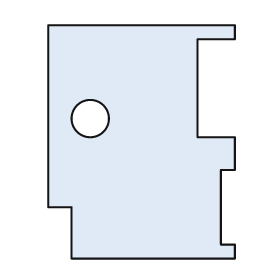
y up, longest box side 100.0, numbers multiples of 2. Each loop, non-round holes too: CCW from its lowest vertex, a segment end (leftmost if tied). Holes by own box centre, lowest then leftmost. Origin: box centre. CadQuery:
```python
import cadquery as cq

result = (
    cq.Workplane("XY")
    .moveTo(-30.0, -50.0)
    .lineTo(40.0, -50.0)
    .lineTo(40.0, -44.0)
    .lineTo(34.0, -44.0)
    .lineTo(34.0, -12.0)
    .lineTo(40.0, -12.0)
    .lineTo(40.0, 2.0)
    .lineTo(24.0, 2.0)
    .lineTo(24.0, 44.0)
    .lineTo(40.0, 44.0)
    .lineTo(40.0, 50.0)
    .lineTo(-40.0, 50.0)
    .lineTo(-40.0, -28.0)
    .lineTo(-30.0, -28.0)
    .close()
    .moveTo(-22.0, 10.0)
    .circle(8.0)
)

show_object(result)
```